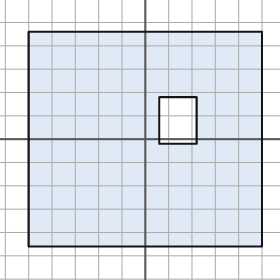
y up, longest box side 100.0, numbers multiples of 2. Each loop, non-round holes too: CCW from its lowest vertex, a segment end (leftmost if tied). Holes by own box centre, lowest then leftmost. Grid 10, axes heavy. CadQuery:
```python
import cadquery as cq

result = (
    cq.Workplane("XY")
    .moveTo(-50.0, -46.0)
    .lineTo(50.0, -46.0)
    .lineTo(50.0, 46.0)
    .lineTo(-50.0, 46.0)
    .close()
    .moveTo(6.0, -2.0)
    .lineTo(22.0, -2.0)
    .lineTo(22.0, 18.0)
    .lineTo(6.0, 18.0)
    .close()
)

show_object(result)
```